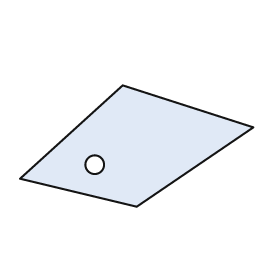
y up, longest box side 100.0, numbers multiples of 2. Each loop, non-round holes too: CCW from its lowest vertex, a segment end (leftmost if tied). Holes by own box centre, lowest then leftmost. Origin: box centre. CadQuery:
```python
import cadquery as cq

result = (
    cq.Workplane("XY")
    .moveTo(0.0, -26.0)
    .lineTo(50.0, 8.0)
    .lineTo(-6.0, 26.0)
    .lineTo(-50.0, -14.0)
    .close()
    .moveTo(-18.0, -8.0)
    .circle(4.0)
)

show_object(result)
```